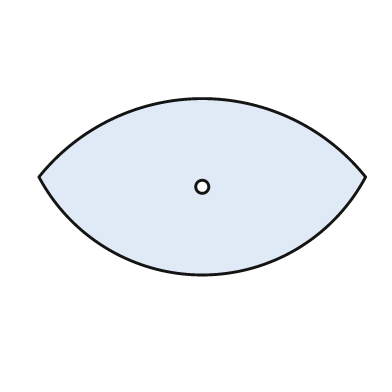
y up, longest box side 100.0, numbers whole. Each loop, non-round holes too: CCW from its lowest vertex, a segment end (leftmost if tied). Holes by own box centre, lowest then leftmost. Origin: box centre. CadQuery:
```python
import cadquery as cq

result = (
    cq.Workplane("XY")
    .moveTo(-50.0, 3.0)
    .threePointArc((0.0, -27.0), (50.0, 3.0))
    .threePointArc((0.0, 27.0), (-50.0, 3.0))
    .close()
    .moveTo(0.0, 0.0)
    .circle(2.0)
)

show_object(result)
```